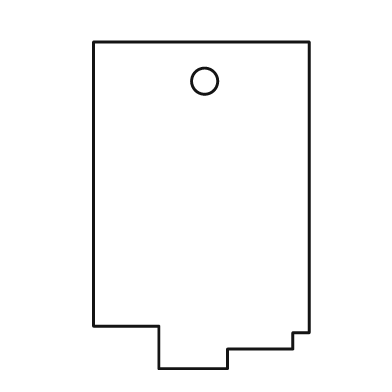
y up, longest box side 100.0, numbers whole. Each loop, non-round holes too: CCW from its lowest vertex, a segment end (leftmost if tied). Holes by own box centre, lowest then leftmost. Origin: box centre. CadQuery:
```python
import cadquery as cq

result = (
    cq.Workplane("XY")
    .moveTo(-13.0, -50.0)
    .lineTo(8.0, -50.0)
    .lineTo(8.0, -44.0)
    .lineTo(28.0, -44.0)
    .lineTo(28.0, -39.0)
    .lineTo(33.0, -39.0)
    .lineTo(33.0, 50.0)
    .lineTo(-33.0, 50.0)
    .lineTo(-33.0, -37.0)
    .lineTo(-13.0, -37.0)
    .close()
    .moveTo(1.0, 38.0)
    .circle(4.0)
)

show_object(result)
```